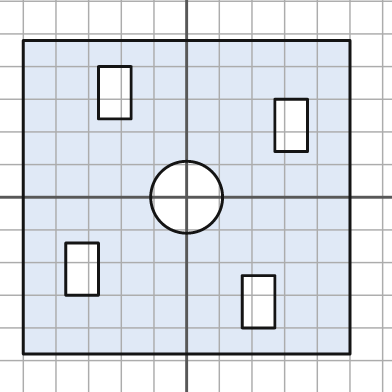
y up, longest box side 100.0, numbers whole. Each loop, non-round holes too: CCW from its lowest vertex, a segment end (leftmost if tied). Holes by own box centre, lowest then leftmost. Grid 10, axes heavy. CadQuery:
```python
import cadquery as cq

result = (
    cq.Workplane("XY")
    .moveTo(-50.0, -48.0)
    .lineTo(50.0, -48.0)
    .lineTo(50.0, 48.0)
    .lineTo(-50.0, 48.0)
    .close()
    .moveTo(17.0, -40.0)
    .lineTo(27.0, -40.0)
    .lineTo(27.0, -24.0)
    .lineTo(17.0, -24.0)
    .close()
    .moveTo(-37.0, -30.0)
    .lineTo(-27.0, -30.0)
    .lineTo(-27.0, -14.0)
    .lineTo(-37.0, -14.0)
    .close()
    .moveTo(0.0, 0.0)
    .circle(11.0)
    .moveTo(27.0, 14.0)
    .lineTo(37.0, 14.0)
    .lineTo(37.0, 30.0)
    .lineTo(27.0, 30.0)
    .close()
    .moveTo(-27.0, 24.0)
    .lineTo(-17.0, 24.0)
    .lineTo(-17.0, 40.0)
    .lineTo(-27.0, 40.0)
    .close()
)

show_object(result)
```